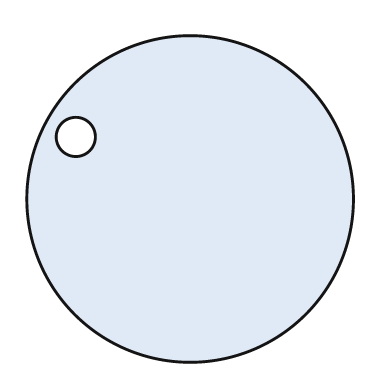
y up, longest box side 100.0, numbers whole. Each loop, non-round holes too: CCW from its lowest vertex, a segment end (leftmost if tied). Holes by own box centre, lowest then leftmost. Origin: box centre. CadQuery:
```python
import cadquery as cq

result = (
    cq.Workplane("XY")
    .moveTo(0.0, 0.0)
    .circle(50.0)
    .moveTo(-35.0, 19.0)
    .circle(6.0)
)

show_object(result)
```